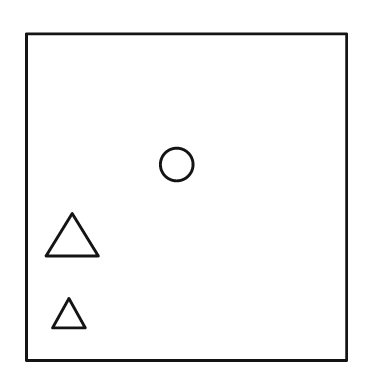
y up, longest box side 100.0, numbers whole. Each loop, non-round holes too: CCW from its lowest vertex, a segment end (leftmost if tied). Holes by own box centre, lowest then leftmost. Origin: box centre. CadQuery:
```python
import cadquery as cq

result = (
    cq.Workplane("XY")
    .moveTo(-49.0, -50.0)
    .lineTo(49.0, -50.0)
    .lineTo(49.0, 50.0)
    .lineTo(-49.0, 50.0)
    .close()
    .moveTo(-41.0, -40.0)
    .lineTo(-31.0, -40.0)
    .lineTo(-36.0, -31.0)
    .close()
    .moveTo(-43.0, -18.0)
    .lineTo(-27.0, -18.0)
    .lineTo(-35.0, -5.0)
    .close()
    .moveTo(-3.0, 10.0)
    .circle(5.0)
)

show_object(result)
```